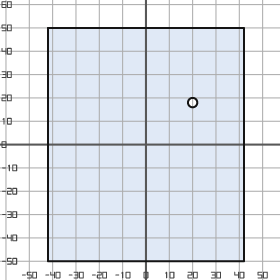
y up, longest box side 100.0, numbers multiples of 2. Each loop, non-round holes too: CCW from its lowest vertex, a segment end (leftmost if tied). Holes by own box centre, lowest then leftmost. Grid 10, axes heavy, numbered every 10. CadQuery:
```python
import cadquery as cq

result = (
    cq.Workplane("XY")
    .moveTo(-42.0, -50.0)
    .lineTo(42.0, -50.0)
    .lineTo(42.0, 50.0)
    .lineTo(-42.0, 50.0)
    .close()
    .moveTo(20.0, 18.0)
    .circle(2.0)
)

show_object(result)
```